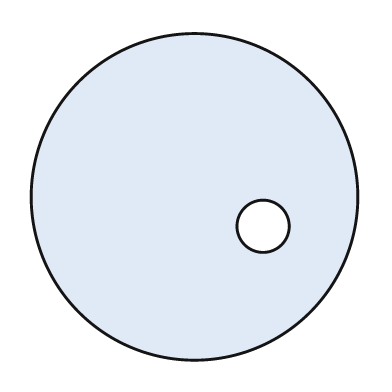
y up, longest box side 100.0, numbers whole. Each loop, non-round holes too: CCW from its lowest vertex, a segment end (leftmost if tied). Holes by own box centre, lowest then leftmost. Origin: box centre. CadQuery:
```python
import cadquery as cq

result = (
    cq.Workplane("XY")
    .moveTo(0.0, 0.0)
    .circle(50.0)
    .moveTo(21.0, -9.0)
    .circle(8.0)
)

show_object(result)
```